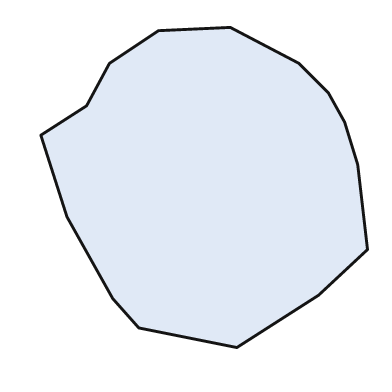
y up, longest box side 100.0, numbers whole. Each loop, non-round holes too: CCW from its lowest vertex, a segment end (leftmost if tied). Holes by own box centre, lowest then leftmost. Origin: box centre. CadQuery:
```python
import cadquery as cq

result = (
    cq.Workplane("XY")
    .moveTo(10.0, -49.0)
    .lineTo(35.0, -33.0)
    .lineTo(50.0, -19.0)
    .lineTo(47.0, 7.0)
    .lineTo(43.0, 20.0)
    .lineTo(38.0, 29.0)
    .lineTo(29.0, 38.0)
    .lineTo(8.0, 49.0)
    .lineTo(-14.0, 48.0)
    .lineTo(-29.0, 38.0)
    .lineTo(-36.0, 25.0)
    .lineTo(-50.0, 16.0)
    .lineTo(-42.0, -9.0)
    .lineTo(-28.0, -34.0)
    .lineTo(-20.0, -43.0)
    .close()
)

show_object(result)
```